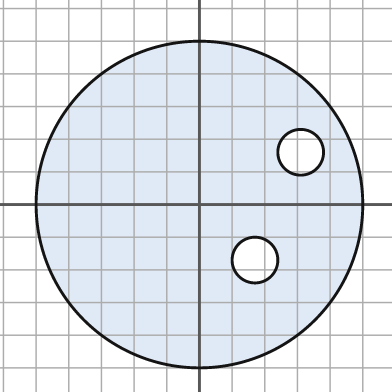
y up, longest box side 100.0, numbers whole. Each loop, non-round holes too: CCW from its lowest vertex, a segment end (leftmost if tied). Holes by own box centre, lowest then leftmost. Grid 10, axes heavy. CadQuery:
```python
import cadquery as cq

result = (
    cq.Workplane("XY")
    .moveTo(0.0, 0.0)
    .circle(50.0)
    .moveTo(17.0, -17.0)
    .circle(7.0)
    .moveTo(31.0, 16.0)
    .circle(7.0)
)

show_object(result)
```